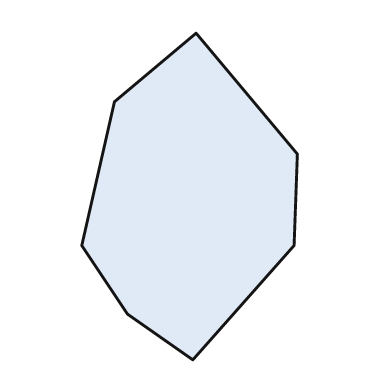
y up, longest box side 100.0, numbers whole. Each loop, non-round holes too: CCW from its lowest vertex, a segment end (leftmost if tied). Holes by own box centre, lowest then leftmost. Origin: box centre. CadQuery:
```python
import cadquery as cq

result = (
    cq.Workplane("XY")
    .moveTo(1.0, -50.0)
    .lineTo(32.0, -15.0)
    .lineTo(33.0, 13.0)
    .lineTo(2.0, 50.0)
    .lineTo(-23.0, 29.0)
    .lineTo(-33.0, -15.0)
    .lineTo(-19.0, -36.0)
    .close()
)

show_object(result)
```